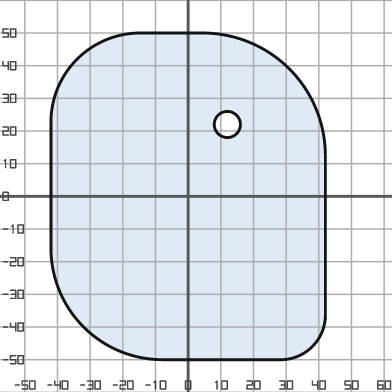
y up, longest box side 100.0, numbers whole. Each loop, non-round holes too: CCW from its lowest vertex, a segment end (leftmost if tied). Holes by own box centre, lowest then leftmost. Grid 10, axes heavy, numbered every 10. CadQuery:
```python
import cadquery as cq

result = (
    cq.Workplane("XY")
    .moveTo(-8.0, -50.0)
    .lineTo(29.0, -50.0)
    .threePointArc((38.0, -46.0), (42.0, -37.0))
    .lineTo(42.0, 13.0)
    .threePointArc((31.0, 39.0), (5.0, 50.0))
    .lineTo(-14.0, 50.0)
    .threePointArc((-34.0, 42.0), (-42.0, 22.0))
    .lineTo(-42.0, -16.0)
    .threePointArc((-32.0, -40.0), (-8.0, -50.0))
    .close()
    .moveTo(12.0, 22.0)
    .circle(4.0)
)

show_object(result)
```